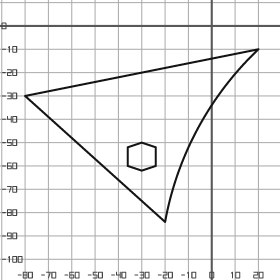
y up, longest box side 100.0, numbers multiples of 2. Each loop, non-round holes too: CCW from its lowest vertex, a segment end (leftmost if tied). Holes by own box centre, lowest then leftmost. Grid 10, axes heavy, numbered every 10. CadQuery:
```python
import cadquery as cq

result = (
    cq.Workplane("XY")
    .moveTo(-20.0, -84.0)
    .threePointArc((-6.0, -44.0), (20.0, -10.0))
    .lineTo(-80.0, -30.0)
    .close()
    .moveTo(-30.0, -62.0)
    .lineTo(-24.0, -60.0)
    .lineTo(-24.0, -52.0)
    .lineTo(-30.0, -50.0)
    .lineTo(-36.0, -52.0)
    .lineTo(-36.0, -60.0)
    .close()
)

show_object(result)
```